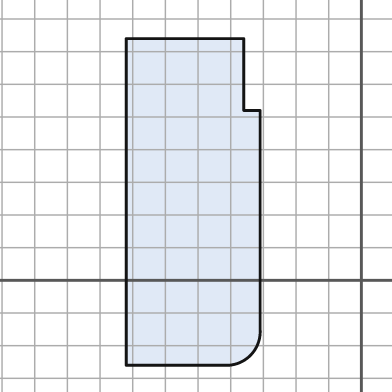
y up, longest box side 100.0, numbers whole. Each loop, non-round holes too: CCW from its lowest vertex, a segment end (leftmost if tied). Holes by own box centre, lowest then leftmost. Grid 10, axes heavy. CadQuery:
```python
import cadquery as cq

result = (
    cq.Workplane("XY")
    .moveTo(-72.0, -26.0)
    .lineTo(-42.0, -26.0)
    .threePointArc((-34.0, -23.0), (-31.0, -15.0))
    .lineTo(-31.0, 52.0)
    .lineTo(-36.0, 52.0)
    .lineTo(-36.0, 74.0)
    .lineTo(-72.0, 74.0)
    .close()
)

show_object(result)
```